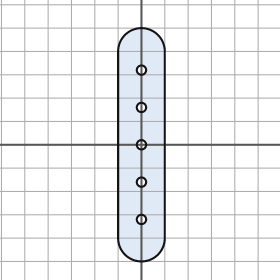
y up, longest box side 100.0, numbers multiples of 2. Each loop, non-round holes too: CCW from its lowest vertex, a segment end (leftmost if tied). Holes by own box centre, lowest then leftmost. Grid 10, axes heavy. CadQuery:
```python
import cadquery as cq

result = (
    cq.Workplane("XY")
    .moveTo(-10.0, -40.0)
    .threePointArc((0.0, -50.0), (10.0, -40.0))
    .lineTo(10.0, 40.0)
    .threePointArc((0.0, 50.0), (-10.0, 40.0))
    .close()
    .moveTo(0.0, -32.0)
    .circle(2.0)
    .moveTo(0.0, -16.0)
    .circle(2.0)
    .moveTo(0.0, 0.0)
    .circle(2.0)
    .moveTo(0.0, 16.0)
    .circle(2.0)
    .moveTo(0.0, 32.0)
    .circle(2.0)
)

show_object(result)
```